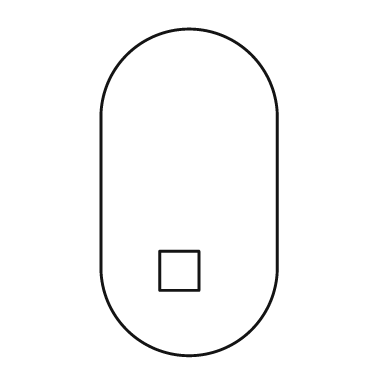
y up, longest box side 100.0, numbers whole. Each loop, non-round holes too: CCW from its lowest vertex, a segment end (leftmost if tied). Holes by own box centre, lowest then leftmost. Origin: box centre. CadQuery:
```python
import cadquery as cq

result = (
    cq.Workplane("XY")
    .moveTo(-27.0, -23.0)
    .threePointArc((0.0, -50.0), (27.0, -23.0))
    .lineTo(27.0, 23.0)
    .threePointArc((0.0, 50.0), (-27.0, 23.0))
    .close()
    .moveTo(-9.0, -30.0)
    .lineTo(3.0, -30.0)
    .lineTo(3.0, -18.0)
    .lineTo(-9.0, -18.0)
    .close()
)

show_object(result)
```